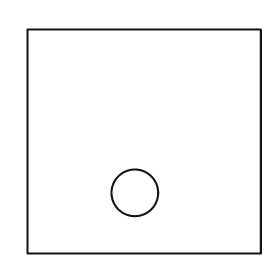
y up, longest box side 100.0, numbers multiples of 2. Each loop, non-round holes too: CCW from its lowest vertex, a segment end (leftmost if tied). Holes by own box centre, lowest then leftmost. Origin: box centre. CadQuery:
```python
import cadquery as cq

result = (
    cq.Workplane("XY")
    .moveTo(-50.0, -48.0)
    .lineTo(50.0, -48.0)
    .lineTo(50.0, 48.0)
    .lineTo(-50.0, 48.0)
    .close()
    .moveTo(-4.0, -22.0)
    .circle(10.0)
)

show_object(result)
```